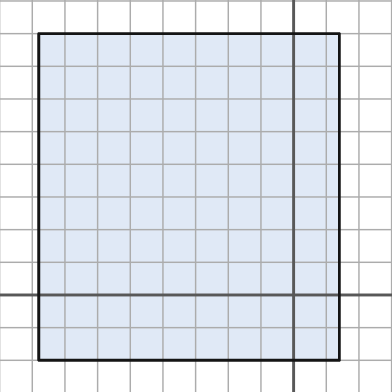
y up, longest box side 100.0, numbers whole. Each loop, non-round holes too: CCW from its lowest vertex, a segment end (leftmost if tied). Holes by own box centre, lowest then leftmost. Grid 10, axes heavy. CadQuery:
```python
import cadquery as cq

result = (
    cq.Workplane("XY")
    .moveTo(-78.0, -20.0)
    .lineTo(14.0, -20.0)
    .lineTo(14.0, 80.0)
    .lineTo(-78.0, 80.0)
    .close()
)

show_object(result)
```